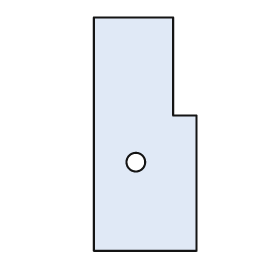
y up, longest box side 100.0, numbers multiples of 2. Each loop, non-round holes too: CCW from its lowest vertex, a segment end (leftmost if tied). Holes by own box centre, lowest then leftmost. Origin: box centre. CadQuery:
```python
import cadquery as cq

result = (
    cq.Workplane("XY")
    .moveTo(-22.0, -50.0)
    .lineTo(22.0, -50.0)
    .lineTo(22.0, 8.0)
    .lineTo(12.0, 8.0)
    .lineTo(12.0, 50.0)
    .lineTo(-22.0, 50.0)
    .close()
    .moveTo(-4.0, -12.0)
    .circle(4.0)
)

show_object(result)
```